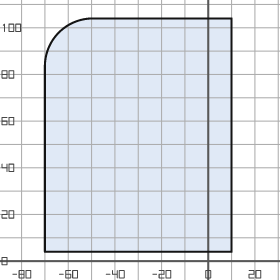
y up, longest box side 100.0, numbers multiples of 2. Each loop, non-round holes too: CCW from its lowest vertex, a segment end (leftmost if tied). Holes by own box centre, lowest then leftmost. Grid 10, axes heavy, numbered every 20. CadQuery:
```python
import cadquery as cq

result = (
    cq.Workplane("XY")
    .moveTo(-70.0, 4.0)
    .lineTo(10.0, 4.0)
    .lineTo(10.0, 104.0)
    .lineTo(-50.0, 104.0)
    .threePointArc((-64.0, 98.0), (-70.0, 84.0))
    .close()
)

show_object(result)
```